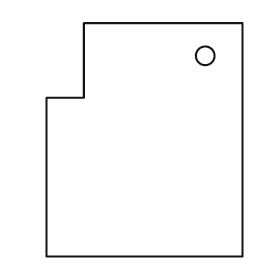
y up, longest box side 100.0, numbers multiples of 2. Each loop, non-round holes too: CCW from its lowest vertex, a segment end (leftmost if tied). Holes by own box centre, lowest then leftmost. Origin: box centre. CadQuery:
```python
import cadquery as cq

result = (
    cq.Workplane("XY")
    .moveTo(-42.0, -50.0)
    .lineTo(42.0, -50.0)
    .lineTo(42.0, 50.0)
    .lineTo(-26.0, 50.0)
    .lineTo(-26.0, 18.0)
    .lineTo(-42.0, 18.0)
    .close()
    .moveTo(26.0, 36.0)
    .circle(4.0)
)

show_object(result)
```